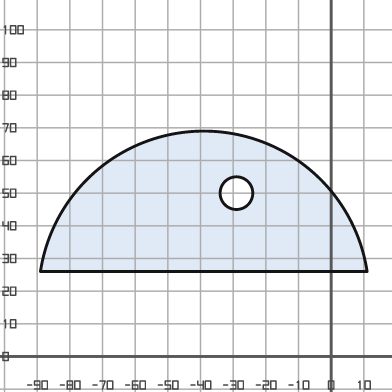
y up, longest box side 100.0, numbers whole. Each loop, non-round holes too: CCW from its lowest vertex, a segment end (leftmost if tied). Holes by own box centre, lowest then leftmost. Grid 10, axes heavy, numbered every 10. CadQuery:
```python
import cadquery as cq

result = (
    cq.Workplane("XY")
    .moveTo(-89.0, 26.0)
    .lineTo(11.0, 26.0)
    .threePointArc((-39.0, 69.0), (-89.0, 26.0))
    .close()
    .moveTo(-29.0, 50.0)
    .circle(5.0)
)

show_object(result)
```